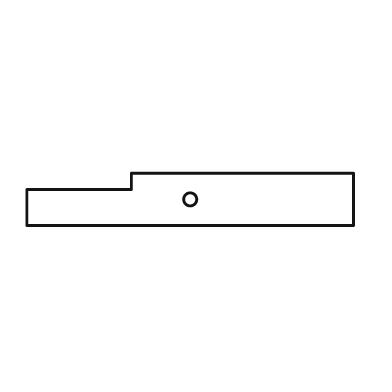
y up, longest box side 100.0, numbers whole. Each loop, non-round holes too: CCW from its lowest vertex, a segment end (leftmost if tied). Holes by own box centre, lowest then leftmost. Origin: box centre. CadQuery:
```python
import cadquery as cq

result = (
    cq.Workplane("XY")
    .moveTo(-50.0, -8.0)
    .lineTo(50.0, -8.0)
    .lineTo(50.0, 8.0)
    .lineTo(-18.0, 8.0)
    .lineTo(-18.0, 3.0)
    .lineTo(-50.0, 3.0)
    .close()
    .moveTo(0.0, 0.0)
    .circle(2.0)
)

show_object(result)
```